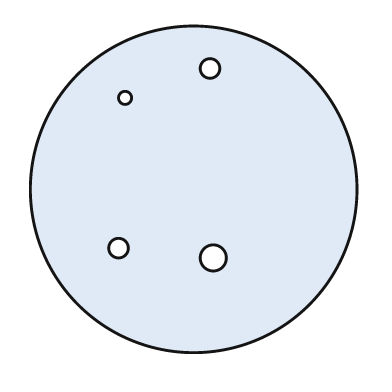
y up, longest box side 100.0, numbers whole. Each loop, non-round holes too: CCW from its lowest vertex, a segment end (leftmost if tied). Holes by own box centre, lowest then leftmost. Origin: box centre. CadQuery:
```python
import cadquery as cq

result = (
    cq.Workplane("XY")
    .moveTo(0.0, 0.0)
    .circle(50.0)
    .moveTo(6.0, -21.0)
    .circle(4.0)
    .moveTo(-23.0, -18.0)
    .circle(3.0)
    .moveTo(-21.0, 28.0)
    .circle(2.0)
    .moveTo(5.0, 37.0)
    .circle(3.0)
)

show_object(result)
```